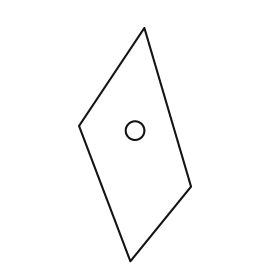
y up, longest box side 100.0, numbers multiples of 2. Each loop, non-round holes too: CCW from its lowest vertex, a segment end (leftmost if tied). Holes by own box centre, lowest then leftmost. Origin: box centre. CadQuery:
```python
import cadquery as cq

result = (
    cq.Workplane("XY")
    .moveTo(-2.0, -50.0)
    .lineTo(24.0, -18.0)
    .lineTo(4.0, 50.0)
    .lineTo(-24.0, 8.0)
    .close()
    .moveTo(0.0, 6.0)
    .circle(4.0)
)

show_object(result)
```